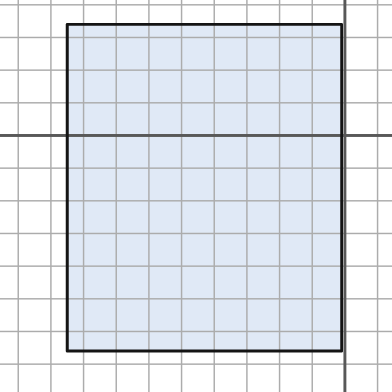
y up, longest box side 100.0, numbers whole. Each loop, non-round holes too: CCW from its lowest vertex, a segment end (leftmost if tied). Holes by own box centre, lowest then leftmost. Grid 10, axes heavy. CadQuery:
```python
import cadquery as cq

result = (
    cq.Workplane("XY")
    .moveTo(-85.0, -66.0)
    .lineTo(-1.0, -66.0)
    .lineTo(-1.0, 34.0)
    .lineTo(-85.0, 34.0)
    .close()
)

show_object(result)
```